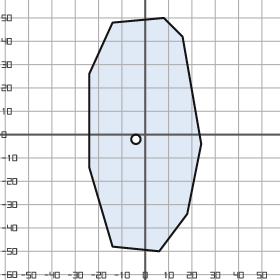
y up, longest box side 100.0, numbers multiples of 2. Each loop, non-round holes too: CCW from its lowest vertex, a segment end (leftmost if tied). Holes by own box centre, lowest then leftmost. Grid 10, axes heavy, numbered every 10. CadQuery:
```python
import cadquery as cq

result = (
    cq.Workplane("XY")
    .moveTo(6.0, -50.0)
    .lineTo(18.0, -34.0)
    .lineTo(24.0, -4.0)
    .lineTo(16.0, 42.0)
    .lineTo(8.0, 50.0)
    .lineTo(-14.0, 48.0)
    .lineTo(-24.0, 26.0)
    .lineTo(-24.0, -14.0)
    .lineTo(-14.0, -48.0)
    .close()
    .moveTo(-4.0, -2.0)
    .circle(2.0)
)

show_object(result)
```